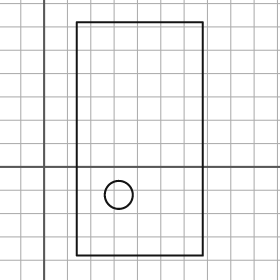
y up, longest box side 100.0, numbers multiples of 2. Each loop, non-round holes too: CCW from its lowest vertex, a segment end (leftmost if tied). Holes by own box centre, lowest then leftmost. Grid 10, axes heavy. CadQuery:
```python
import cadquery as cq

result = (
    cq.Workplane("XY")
    .moveTo(14.0, -38.0)
    .lineTo(68.0, -38.0)
    .lineTo(68.0, 62.0)
    .lineTo(14.0, 62.0)
    .close()
    .moveTo(32.0, -12.0)
    .circle(6.0)
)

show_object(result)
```